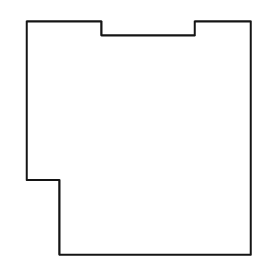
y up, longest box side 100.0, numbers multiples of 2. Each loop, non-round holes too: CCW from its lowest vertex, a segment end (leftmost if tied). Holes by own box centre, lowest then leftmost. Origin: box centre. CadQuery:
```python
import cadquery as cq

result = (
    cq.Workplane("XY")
    .moveTo(-34.0, -50.0)
    .lineTo(48.0, -50.0)
    .lineTo(48.0, 50.0)
    .lineTo(24.0, 50.0)
    .lineTo(24.0, 44.0)
    .lineTo(-16.0, 44.0)
    .lineTo(-16.0, 50.0)
    .lineTo(-48.0, 50.0)
    .lineTo(-48.0, -18.0)
    .lineTo(-34.0, -18.0)
    .close()
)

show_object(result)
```